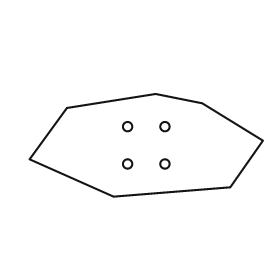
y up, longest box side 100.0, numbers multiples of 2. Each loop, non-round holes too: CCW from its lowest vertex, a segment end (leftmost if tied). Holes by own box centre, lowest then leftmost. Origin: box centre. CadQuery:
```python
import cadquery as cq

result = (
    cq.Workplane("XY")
    .moveTo(-14.0, -22.0)
    .lineTo(36.0, -18.0)
    .lineTo(50.0, 2.0)
    .lineTo(24.0, 18.0)
    .lineTo(4.0, 22.0)
    .lineTo(-34.0, 16.0)
    .lineTo(-50.0, -6.0)
    .close()
    .moveTo(-8.0, -8.0)
    .circle(2.0)
    .moveTo(8.0, -8.0)
    .circle(2.0)
    .moveTo(-8.0, 8.0)
    .circle(2.0)
    .moveTo(8.0, 8.0)
    .circle(2.0)
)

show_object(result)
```